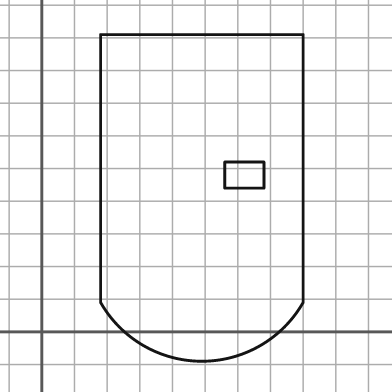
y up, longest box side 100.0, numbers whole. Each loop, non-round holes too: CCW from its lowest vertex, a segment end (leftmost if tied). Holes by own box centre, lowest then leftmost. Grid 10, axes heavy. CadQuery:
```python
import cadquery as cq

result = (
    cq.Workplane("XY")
    .moveTo(18.0, 9.0)
    .threePointArc((49.0, -9.0), (80.0, 9.0))
    .lineTo(80.0, 91.0)
    .lineTo(18.0, 91.0)
    .close()
    .moveTo(56.0, 44.0)
    .lineTo(68.0, 44.0)
    .lineTo(68.0, 52.0)
    .lineTo(56.0, 52.0)
    .close()
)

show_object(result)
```